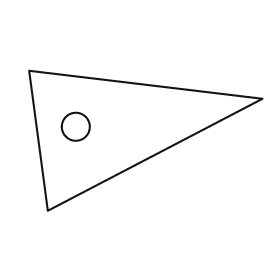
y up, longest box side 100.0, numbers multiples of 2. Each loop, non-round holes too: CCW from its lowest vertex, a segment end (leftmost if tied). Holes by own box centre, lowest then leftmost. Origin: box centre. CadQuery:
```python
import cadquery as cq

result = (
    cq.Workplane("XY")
    .moveTo(-42.0, -30.0)
    .lineTo(50.0, 18.0)
    .lineTo(-50.0, 30.0)
    .close()
    .moveTo(-30.0, 6.0)
    .circle(6.0)
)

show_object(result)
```